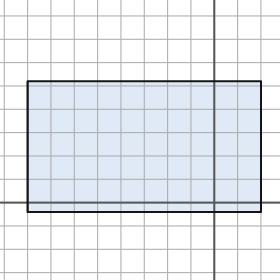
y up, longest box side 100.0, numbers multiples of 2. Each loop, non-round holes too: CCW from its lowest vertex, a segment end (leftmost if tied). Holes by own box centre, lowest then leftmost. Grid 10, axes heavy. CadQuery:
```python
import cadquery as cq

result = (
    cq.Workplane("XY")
    .moveTo(-80.0, -4.0)
    .lineTo(20.0, -4.0)
    .lineTo(20.0, 52.0)
    .lineTo(-80.0, 52.0)
    .close()
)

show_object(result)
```